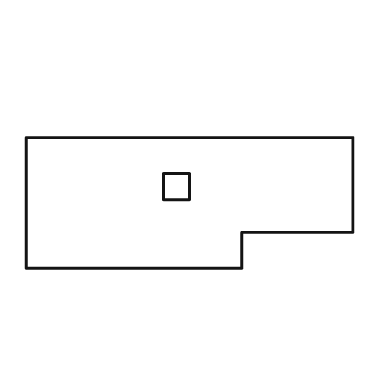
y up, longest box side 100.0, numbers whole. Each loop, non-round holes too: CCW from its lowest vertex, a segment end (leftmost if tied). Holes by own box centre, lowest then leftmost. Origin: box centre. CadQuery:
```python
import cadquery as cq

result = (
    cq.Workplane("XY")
    .moveTo(-50.0, -20.0)
    .lineTo(16.0, -20.0)
    .lineTo(16.0, -9.0)
    .lineTo(50.0, -9.0)
    .lineTo(50.0, 20.0)
    .lineTo(-50.0, 20.0)
    .close()
    .moveTo(-8.0, 1.0)
    .lineTo(0.0, 1.0)
    .lineTo(0.0, 9.0)
    .lineTo(-8.0, 9.0)
    .close()
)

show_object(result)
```